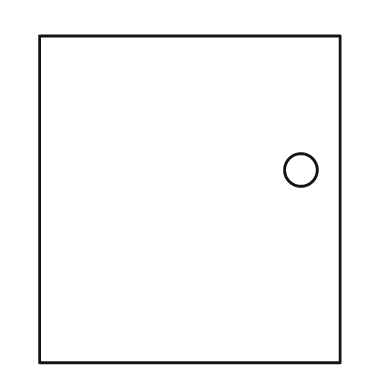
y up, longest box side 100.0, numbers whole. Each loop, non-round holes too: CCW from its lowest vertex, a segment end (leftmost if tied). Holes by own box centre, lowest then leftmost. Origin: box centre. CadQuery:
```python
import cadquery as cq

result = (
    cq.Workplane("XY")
    .moveTo(-46.0, -50.0)
    .lineTo(46.0, -50.0)
    .lineTo(46.0, 50.0)
    .lineTo(-46.0, 50.0)
    .close()
    .moveTo(34.0, 9.0)
    .circle(5.0)
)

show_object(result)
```